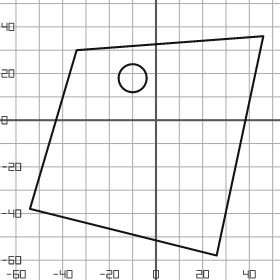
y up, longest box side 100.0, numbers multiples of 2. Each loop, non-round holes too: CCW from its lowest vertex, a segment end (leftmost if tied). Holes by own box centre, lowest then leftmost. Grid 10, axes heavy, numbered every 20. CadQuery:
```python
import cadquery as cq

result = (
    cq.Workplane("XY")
    .moveTo(26.0, -58.0)
    .lineTo(46.0, 36.0)
    .lineTo(-34.0, 30.0)
    .lineTo(-54.0, -38.0)
    .close()
    .moveTo(-10.0, 18.0)
    .circle(6.0)
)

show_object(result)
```